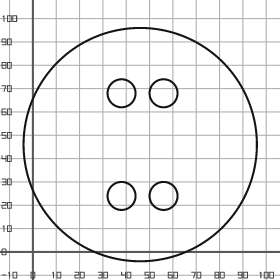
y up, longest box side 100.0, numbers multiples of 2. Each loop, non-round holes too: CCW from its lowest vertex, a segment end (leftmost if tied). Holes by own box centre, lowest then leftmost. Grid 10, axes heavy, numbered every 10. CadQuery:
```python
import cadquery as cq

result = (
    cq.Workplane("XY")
    .moveTo(46.0, 46.0)
    .circle(50.0)
    .moveTo(38.0, 24.0)
    .circle(6.0)
    .moveTo(56.0, 24.0)
    .circle(6.0)
    .moveTo(38.0, 68.0)
    .circle(6.0)
    .moveTo(56.0, 68.0)
    .circle(6.0)
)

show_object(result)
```